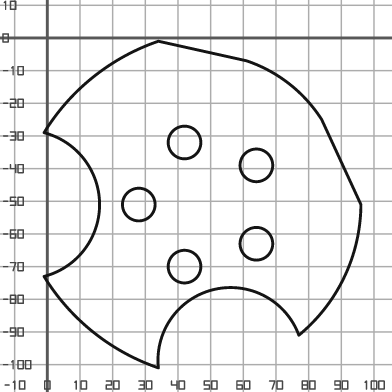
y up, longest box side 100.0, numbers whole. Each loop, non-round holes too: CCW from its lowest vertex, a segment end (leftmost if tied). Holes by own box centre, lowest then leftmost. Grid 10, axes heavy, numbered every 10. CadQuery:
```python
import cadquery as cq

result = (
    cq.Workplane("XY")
    .moveTo(34.0, -101.0)
    .threePointArc((51.0, -77.0), (77.0, -91.0))
    .threePointArc((91.0, -73.0), (96.0, -51.0))
    .lineTo(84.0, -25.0)
    .threePointArc((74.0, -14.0), (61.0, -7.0))
    .lineTo(34.0, -1.0)
    .threePointArc((14.0, -12.0), (-1.0, -29.0))
    .threePointArc((16.0, -51.0), (-1.0, -73.0))
    .threePointArc((14.0, -90.0), (34.0, -101.0))
    .close()
    .moveTo(42.0, -70.0)
    .circle(5.0)
    .moveTo(64.0, -63.0)
    .circle(5.0)
    .moveTo(28.0, -51.0)
    .circle(5.0)
    .moveTo(64.0, -39.0)
    .circle(5.0)
    .moveTo(42.0, -32.0)
    .circle(5.0)
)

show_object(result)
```